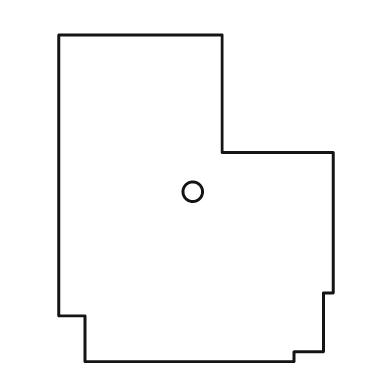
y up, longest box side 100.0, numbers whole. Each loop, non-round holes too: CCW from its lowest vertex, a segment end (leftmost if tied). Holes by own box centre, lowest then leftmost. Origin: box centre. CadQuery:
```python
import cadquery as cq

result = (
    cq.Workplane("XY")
    .moveTo(-34.0, -50.0)
    .lineTo(30.0, -50.0)
    .lineTo(30.0, -47.0)
    .lineTo(39.0, -47.0)
    .lineTo(39.0, -29.0)
    .lineTo(42.0, -29.0)
    .lineTo(42.0, 14.0)
    .lineTo(8.0, 14.0)
    .lineTo(8.0, 50.0)
    .lineTo(-42.0, 50.0)
    .lineTo(-42.0, -36.0)
    .lineTo(-34.0, -36.0)
    .close()
    .moveTo(-1.0, 2.0)
    .circle(3.0)
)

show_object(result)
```